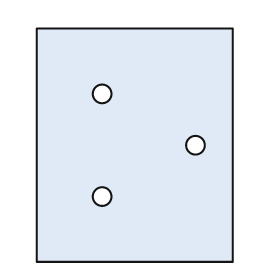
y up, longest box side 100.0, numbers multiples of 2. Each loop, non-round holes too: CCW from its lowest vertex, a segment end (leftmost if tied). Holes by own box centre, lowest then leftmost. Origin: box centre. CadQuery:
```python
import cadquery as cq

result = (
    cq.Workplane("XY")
    .moveTo(-42.0, -50.0)
    .lineTo(42.0, -50.0)
    .lineTo(42.0, 50.0)
    .lineTo(-42.0, 50.0)
    .close()
    .moveTo(-14.0, -22.0)
    .circle(4.0)
    .moveTo(26.0, 0.0)
    .circle(4.0)
    .moveTo(-14.0, 22.0)
    .circle(4.0)
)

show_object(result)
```